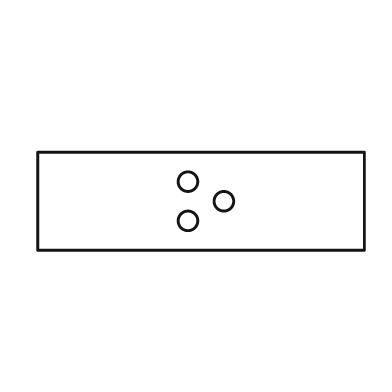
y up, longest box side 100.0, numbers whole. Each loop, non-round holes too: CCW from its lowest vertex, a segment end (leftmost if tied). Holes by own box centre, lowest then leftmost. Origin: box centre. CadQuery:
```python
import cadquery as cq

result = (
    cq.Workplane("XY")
    .moveTo(-50.0, -15.0)
    .lineTo(50.0, -15.0)
    .lineTo(50.0, 15.0)
    .lineTo(-50.0, 15.0)
    .close()
    .moveTo(-4.0, -6.0)
    .circle(3.0)
    .moveTo(7.0, 0.0)
    .circle(3.0)
    .moveTo(-4.0, 6.0)
    .circle(3.0)
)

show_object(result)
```